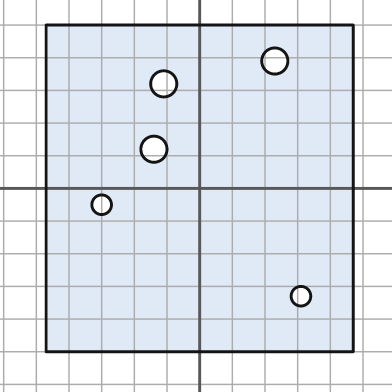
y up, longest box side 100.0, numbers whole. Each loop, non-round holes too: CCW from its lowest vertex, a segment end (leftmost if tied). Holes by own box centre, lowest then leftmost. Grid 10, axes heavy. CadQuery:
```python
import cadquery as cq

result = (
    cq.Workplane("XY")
    .moveTo(-47.0, -50.0)
    .lineTo(47.0, -50.0)
    .lineTo(47.0, 50.0)
    .lineTo(-47.0, 50.0)
    .close()
    .moveTo(31.0, -33.0)
    .circle(3.0)
    .moveTo(-30.0, -5.0)
    .circle(3.0)
    .moveTo(-14.0, 12.0)
    .circle(4.0)
    .moveTo(-11.0, 32.0)
    .circle(4.0)
    .moveTo(23.0, 39.0)
    .circle(4.0)
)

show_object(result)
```